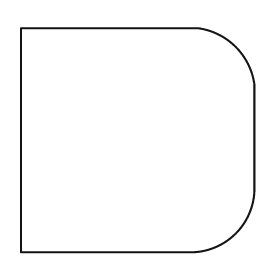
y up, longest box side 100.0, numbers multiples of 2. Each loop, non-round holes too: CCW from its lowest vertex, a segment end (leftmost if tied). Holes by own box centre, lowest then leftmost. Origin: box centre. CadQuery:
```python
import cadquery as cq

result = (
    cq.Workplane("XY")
    .moveTo(-50.0, -48.0)
    .lineTo(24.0, -48.0)
    .threePointArc((42.0, -40.0), (50.0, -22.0))
    .lineTo(50.0, 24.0)
    .threePointArc((42.0, 40.0), (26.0, 48.0))
    .lineTo(-50.0, 48.0)
    .close()
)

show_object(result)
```